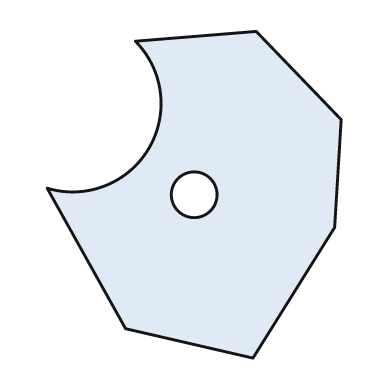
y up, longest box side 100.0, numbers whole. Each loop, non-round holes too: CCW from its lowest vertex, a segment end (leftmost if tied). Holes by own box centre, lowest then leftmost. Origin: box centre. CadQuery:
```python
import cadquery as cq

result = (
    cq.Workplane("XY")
    .moveTo(18.0, -50.0)
    .lineTo(43.0, -10.0)
    .lineTo(45.0, 23.0)
    .lineTo(19.0, 50.0)
    .lineTo(-18.0, 47.0)
    .threePointArc((-14.0, 14.0), (-45.0, 2.0))
    .lineTo(-21.0, -41.0)
    .close()
    .moveTo(0.0, 0.0)
    .circle(7.0)
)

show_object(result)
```